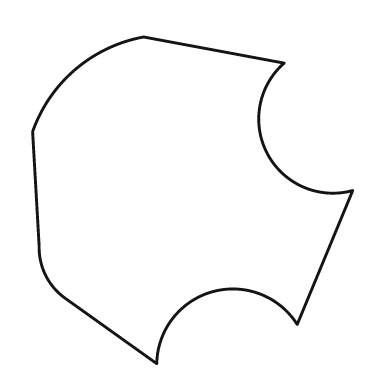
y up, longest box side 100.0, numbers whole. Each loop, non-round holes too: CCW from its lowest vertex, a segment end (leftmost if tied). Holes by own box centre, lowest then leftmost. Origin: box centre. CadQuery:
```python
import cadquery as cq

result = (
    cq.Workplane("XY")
    .moveTo(-11.0, -50.0)
    .threePointArc((6.0, -28.0), (32.0, -38.0))
    .lineTo(49.0, 3.0)
    .threePointArc((23.0, 14.0), (28.0, 42.0))
    .lineTo(-15.0, 50.0)
    .threePointArc((-36.0, 40.0), (-49.0, 21.0))
    .lineTo(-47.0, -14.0)
    .threePointArc((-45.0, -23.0), (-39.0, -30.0))
    .close()
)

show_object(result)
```